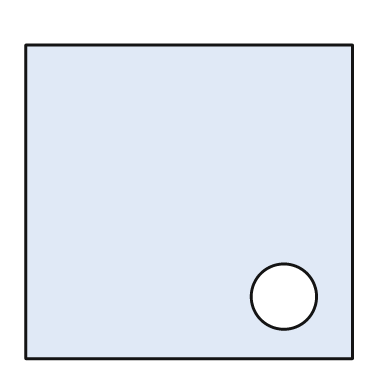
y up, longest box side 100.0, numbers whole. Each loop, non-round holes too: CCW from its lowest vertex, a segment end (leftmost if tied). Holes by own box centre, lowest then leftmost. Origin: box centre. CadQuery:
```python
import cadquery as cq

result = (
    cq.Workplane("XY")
    .moveTo(-50.0, -48.0)
    .lineTo(50.0, -48.0)
    .lineTo(50.0, 48.0)
    .lineTo(-50.0, 48.0)
    .close()
    .moveTo(29.0, -29.0)
    .circle(10.0)
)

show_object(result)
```